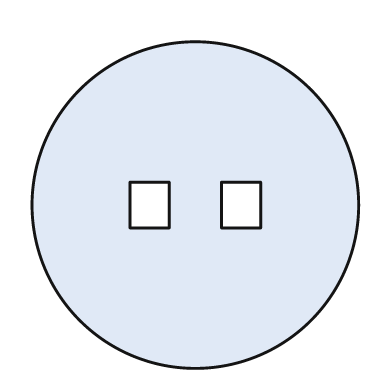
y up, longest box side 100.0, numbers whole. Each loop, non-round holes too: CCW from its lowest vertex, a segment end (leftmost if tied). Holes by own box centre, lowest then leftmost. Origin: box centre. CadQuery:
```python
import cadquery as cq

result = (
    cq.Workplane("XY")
    .moveTo(0.0, 0.0)
    .circle(50.0)
    .moveTo(-20.0, -7.0)
    .lineTo(-8.0, -7.0)
    .lineTo(-8.0, 7.0)
    .lineTo(-20.0, 7.0)
    .close()
    .moveTo(8.0, -7.0)
    .lineTo(20.0, -7.0)
    .lineTo(20.0, 7.0)
    .lineTo(8.0, 7.0)
    .close()
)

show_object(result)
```